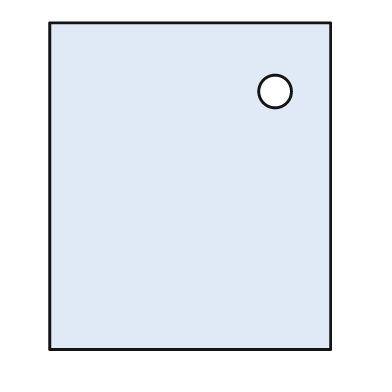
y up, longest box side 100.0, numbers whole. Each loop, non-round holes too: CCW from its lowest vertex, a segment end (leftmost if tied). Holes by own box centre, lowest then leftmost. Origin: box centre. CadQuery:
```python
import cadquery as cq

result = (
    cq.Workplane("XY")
    .moveTo(-43.0, -50.0)
    .lineTo(43.0, -50.0)
    .lineTo(43.0, 50.0)
    .lineTo(-43.0, 50.0)
    .close()
    .moveTo(26.0, 29.0)
    .circle(5.0)
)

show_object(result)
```